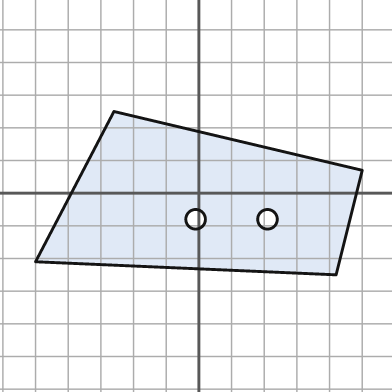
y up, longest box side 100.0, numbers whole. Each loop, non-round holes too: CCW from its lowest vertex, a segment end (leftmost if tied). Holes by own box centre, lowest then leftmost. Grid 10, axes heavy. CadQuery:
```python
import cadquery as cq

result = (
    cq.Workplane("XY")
    .moveTo(42.0, -25.0)
    .lineTo(50.0, 7.0)
    .lineTo(-26.0, 25.0)
    .lineTo(-50.0, -21.0)
    .close()
    .moveTo(-1.0, -8.0)
    .circle(3.0)
    .moveTo(21.0, -8.0)
    .circle(3.0)
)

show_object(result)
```